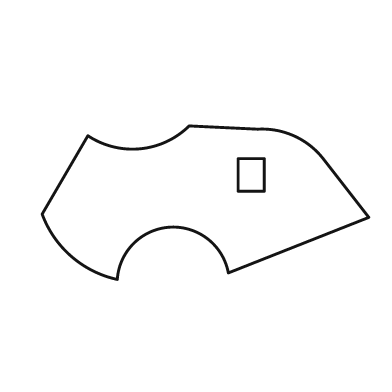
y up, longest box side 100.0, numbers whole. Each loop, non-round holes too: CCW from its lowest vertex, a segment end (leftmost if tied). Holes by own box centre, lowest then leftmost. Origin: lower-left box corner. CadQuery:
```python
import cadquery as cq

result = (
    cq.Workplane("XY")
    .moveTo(23.0, 0.0)
    .threePointArc((39.0, 16.0), (57.0, 2.0))
    .lineTo(100.0, 19.0)
    .lineTo(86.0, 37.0)
    .threePointArc((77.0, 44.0), (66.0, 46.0))
    .lineTo(45.0, 47.0)
    .threePointArc((30.0, 40.0), (14.0, 44.0))
    .lineTo(0.0, 20.0)
    .threePointArc((9.0, 7.0), (23.0, 0.0))
    .close()
    .moveTo(60.0, 27.0)
    .lineTo(68.0, 27.0)
    .lineTo(68.0, 37.0)
    .lineTo(60.0, 37.0)
    .close()
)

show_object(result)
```